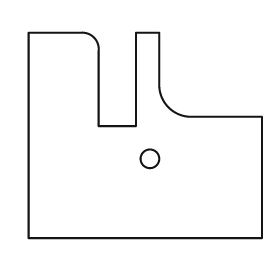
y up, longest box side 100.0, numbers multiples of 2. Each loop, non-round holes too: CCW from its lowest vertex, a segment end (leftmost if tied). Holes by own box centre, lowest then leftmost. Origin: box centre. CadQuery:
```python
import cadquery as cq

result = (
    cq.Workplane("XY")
    .moveTo(-50.0, -44.0)
    .lineTo(50.0, -44.0)
    .lineTo(50.0, 8.0)
    .lineTo(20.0, 8.0)
    .threePointArc((10.0, 12.0), (6.0, 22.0))
    .lineTo(6.0, 44.0)
    .lineTo(-4.0, 44.0)
    .lineTo(-4.0, 4.0)
    .lineTo(-20.0, 4.0)
    .lineTo(-20.0, 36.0)
    .threePointArc((-22.0, 42.0), (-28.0, 44.0))
    .lineTo(-50.0, 44.0)
    .close()
    .moveTo(2.0, -10.0)
    .circle(4.0)
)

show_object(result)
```